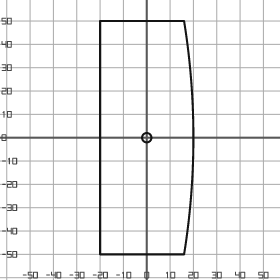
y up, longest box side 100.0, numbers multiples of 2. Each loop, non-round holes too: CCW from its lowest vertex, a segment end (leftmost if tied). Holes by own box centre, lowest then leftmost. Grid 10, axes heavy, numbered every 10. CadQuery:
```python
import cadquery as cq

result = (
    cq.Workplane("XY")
    .moveTo(-20.0, -50.0)
    .lineTo(16.0, -50.0)
    .threePointArc((20.0, 0.0), (16.0, 50.0))
    .lineTo(-20.0, 50.0)
    .close()
    .moveTo(0.0, 0.0)
    .circle(2.0)
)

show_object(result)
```